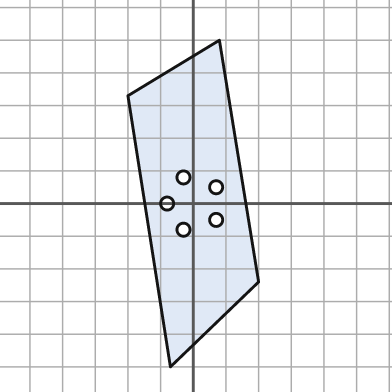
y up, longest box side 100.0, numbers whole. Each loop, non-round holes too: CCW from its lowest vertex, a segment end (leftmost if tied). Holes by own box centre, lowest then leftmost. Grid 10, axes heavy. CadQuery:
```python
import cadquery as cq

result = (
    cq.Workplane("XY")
    .moveTo(-7.0, -50.0)
    .lineTo(20.0, -24.0)
    .lineTo(8.0, 50.0)
    .lineTo(-20.0, 33.0)
    .close()
    .moveTo(-3.0, -8.0)
    .circle(2.0)
    .moveTo(7.0, -5.0)
    .circle(2.0)
    .moveTo(-8.0, 0.0)
    .circle(2.0)
    .moveTo(7.0, 5.0)
    .circle(2.0)
    .moveTo(-3.0, 8.0)
    .circle(2.0)
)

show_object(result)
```